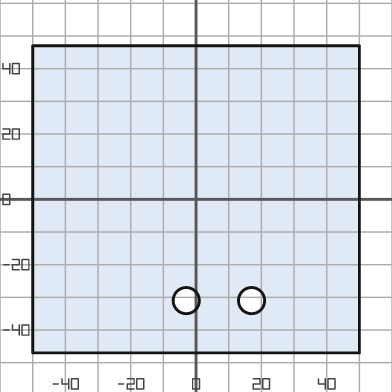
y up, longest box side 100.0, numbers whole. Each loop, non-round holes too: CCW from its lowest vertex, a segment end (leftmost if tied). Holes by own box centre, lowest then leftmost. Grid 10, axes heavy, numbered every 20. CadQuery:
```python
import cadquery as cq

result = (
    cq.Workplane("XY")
    .moveTo(-50.0, -47.0)
    .lineTo(50.0, -47.0)
    .lineTo(50.0, 47.0)
    .lineTo(-50.0, 47.0)
    .close()
    .moveTo(-3.0, -31.0)
    .circle(4.0)
    .moveTo(17.0, -31.0)
    .circle(4.0)
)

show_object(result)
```